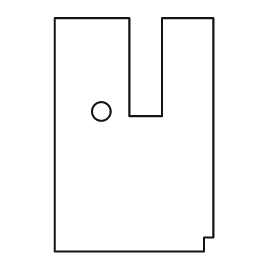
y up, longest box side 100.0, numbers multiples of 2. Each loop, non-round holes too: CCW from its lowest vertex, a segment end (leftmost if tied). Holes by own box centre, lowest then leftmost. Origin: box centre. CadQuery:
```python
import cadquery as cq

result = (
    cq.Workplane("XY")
    .moveTo(-34.0, -50.0)
    .lineTo(30.0, -50.0)
    .lineTo(30.0, -44.0)
    .lineTo(34.0, -44.0)
    .lineTo(34.0, 50.0)
    .lineTo(12.0, 50.0)
    .lineTo(12.0, 8.0)
    .lineTo(-2.0, 8.0)
    .lineTo(-2.0, 50.0)
    .lineTo(-34.0, 50.0)
    .close()
    .moveTo(-14.0, 10.0)
    .circle(4.0)
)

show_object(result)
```